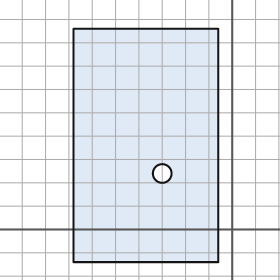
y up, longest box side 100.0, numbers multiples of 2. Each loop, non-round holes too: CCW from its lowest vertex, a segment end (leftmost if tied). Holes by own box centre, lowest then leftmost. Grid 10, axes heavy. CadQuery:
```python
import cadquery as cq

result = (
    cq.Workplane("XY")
    .moveTo(-68.0, -14.0)
    .lineTo(-6.0, -14.0)
    .lineTo(-6.0, 86.0)
    .lineTo(-68.0, 86.0)
    .close()
    .moveTo(-30.0, 24.0)
    .circle(4.0)
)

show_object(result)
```